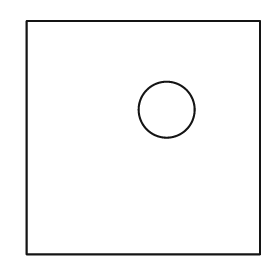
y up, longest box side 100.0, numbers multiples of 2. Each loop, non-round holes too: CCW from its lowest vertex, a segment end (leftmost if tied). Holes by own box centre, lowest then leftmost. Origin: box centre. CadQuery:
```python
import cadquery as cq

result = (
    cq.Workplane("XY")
    .moveTo(-50.0, -50.0)
    .lineTo(50.0, -50.0)
    .lineTo(50.0, 50.0)
    .lineTo(-50.0, 50.0)
    .close()
    .moveTo(10.0, 12.0)
    .circle(12.0)
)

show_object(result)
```